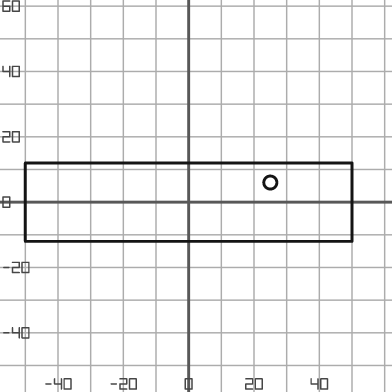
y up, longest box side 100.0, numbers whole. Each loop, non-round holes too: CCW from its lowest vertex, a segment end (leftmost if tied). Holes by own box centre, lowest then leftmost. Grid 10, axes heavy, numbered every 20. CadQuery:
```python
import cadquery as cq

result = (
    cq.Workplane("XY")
    .moveTo(-50.0, -12.0)
    .lineTo(50.0, -12.0)
    .lineTo(50.0, 12.0)
    .lineTo(-50.0, 12.0)
    .close()
    .moveTo(25.0, 6.0)
    .circle(2.0)
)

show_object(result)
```